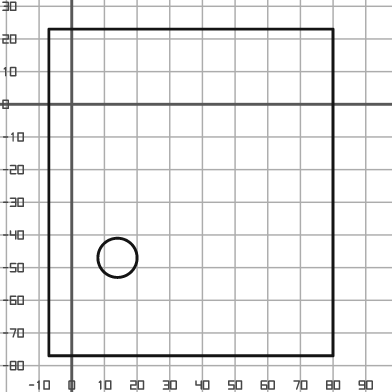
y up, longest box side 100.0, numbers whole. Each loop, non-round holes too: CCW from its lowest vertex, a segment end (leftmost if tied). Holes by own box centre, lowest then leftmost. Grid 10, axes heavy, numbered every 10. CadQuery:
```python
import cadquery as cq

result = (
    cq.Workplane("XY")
    .moveTo(-7.0, -77.0)
    .lineTo(80.0, -77.0)
    .lineTo(80.0, 23.0)
    .lineTo(-7.0, 23.0)
    .close()
    .moveTo(14.0, -47.0)
    .circle(6.0)
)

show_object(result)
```